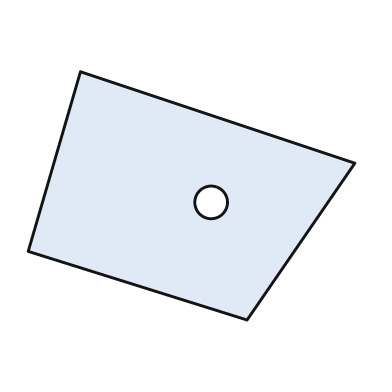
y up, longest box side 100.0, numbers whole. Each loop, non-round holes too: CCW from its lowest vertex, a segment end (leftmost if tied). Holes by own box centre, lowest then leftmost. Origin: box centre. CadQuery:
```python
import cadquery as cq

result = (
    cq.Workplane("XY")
    .moveTo(17.0, -38.0)
    .lineTo(50.0, 10.0)
    .lineTo(-34.0, 38.0)
    .lineTo(-50.0, -17.0)
    .close()
    .moveTo(6.0, -2.0)
    .circle(5.0)
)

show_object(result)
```